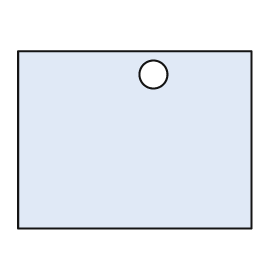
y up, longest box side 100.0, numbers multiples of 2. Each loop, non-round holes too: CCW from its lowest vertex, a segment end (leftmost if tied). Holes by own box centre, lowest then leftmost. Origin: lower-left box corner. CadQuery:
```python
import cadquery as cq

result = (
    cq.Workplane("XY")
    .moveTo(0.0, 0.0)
    .lineTo(100.0, 0.0)
    .lineTo(100.0, 76.0)
    .lineTo(0.0, 76.0)
    .close()
    .moveTo(58.0, 66.0)
    .circle(6.0)
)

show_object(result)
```